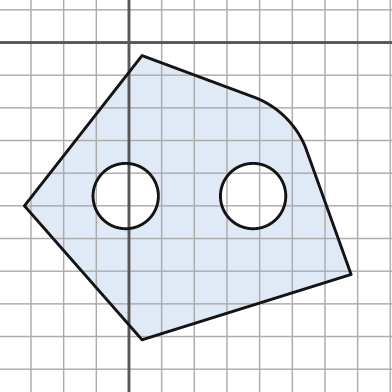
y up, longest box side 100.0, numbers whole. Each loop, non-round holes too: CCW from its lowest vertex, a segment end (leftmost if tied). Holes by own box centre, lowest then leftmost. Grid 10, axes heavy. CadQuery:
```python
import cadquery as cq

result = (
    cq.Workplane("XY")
    .moveTo(4.0, -91.0)
    .lineTo(68.0, -71.0)
    .lineTo(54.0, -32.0)
    .threePointArc((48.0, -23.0), (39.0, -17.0))
    .lineTo(4.0, -4.0)
    .lineTo(-32.0, -50.0)
    .close()
    .moveTo(-1.0, -47.0)
    .circle(10.0)
    .moveTo(38.0, -47.0)
    .circle(10.0)
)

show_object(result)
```